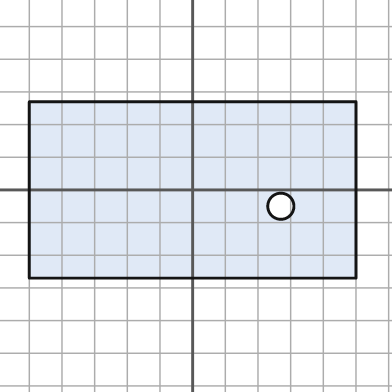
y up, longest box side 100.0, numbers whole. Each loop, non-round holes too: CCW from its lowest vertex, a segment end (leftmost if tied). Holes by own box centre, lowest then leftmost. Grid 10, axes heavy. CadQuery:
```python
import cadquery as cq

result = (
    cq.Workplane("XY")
    .moveTo(-50.0, -27.0)
    .lineTo(50.0, -27.0)
    .lineTo(50.0, 27.0)
    .lineTo(-50.0, 27.0)
    .close()
    .moveTo(27.0, -5.0)
    .circle(4.0)
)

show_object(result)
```